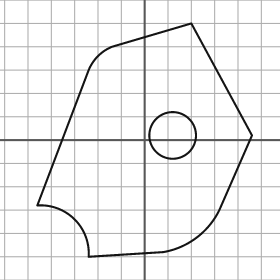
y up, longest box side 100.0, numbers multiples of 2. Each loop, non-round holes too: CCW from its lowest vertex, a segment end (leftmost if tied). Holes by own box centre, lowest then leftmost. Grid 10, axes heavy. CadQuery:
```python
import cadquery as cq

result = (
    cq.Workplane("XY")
    .moveTo(-24.0, -50.0)
    .lineTo(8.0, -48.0)
    .threePointArc((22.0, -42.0), (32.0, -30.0))
    .lineTo(46.0, 2.0)
    .lineTo(20.0, 50.0)
    .lineTo(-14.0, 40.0)
    .threePointArc((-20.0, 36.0), (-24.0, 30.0))
    .lineTo(-46.0, -28.0)
    .threePointArc((-30.0, -34.0), (-24.0, -50.0))
    .close()
    .moveTo(12.0, 2.0)
    .circle(10.0)
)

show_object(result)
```